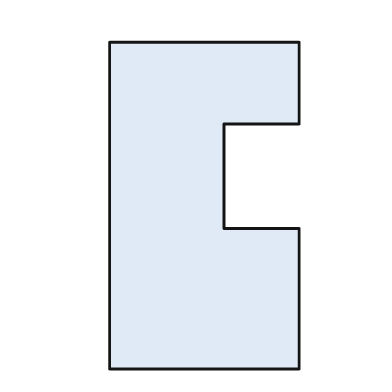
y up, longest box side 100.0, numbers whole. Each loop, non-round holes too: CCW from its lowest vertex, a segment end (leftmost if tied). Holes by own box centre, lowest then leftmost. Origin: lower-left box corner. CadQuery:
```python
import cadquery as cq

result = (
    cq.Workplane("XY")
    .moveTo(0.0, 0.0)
    .lineTo(58.0, 0.0)
    .lineTo(58.0, 43.0)
    .lineTo(35.0, 43.0)
    .lineTo(35.0, 75.0)
    .lineTo(58.0, 75.0)
    .lineTo(58.0, 100.0)
    .lineTo(0.0, 100.0)
    .close()
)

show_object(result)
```